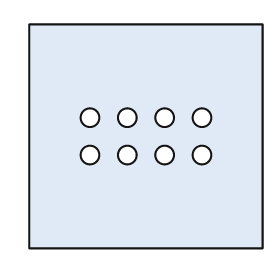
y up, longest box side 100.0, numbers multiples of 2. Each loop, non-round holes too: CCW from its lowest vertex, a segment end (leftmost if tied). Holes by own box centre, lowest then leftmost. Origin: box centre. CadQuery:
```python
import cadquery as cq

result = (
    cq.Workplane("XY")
    .moveTo(-50.0, -48.0)
    .lineTo(50.0, -48.0)
    .lineTo(50.0, 48.0)
    .lineTo(-50.0, 48.0)
    .close()
    .moveTo(-24.0, -8.0)
    .circle(4.0)
    .moveTo(-8.0, -8.0)
    .circle(4.0)
    .moveTo(8.0, -8.0)
    .circle(4.0)
    .moveTo(24.0, -8.0)
    .circle(4.0)
    .moveTo(-24.0, 8.0)
    .circle(4.0)
    .moveTo(-8.0, 8.0)
    .circle(4.0)
    .moveTo(8.0, 8.0)
    .circle(4.0)
    .moveTo(24.0, 8.0)
    .circle(4.0)
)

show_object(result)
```